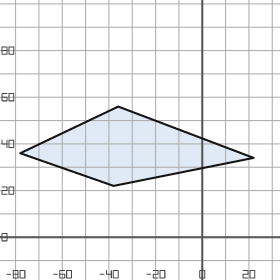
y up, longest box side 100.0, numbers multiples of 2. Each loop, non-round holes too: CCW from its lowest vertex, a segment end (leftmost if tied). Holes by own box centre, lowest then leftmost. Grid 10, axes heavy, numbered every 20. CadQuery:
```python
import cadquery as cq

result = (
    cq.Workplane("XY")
    .moveTo(-38.0, 22.0)
    .lineTo(22.0, 34.0)
    .lineTo(-36.0, 56.0)
    .lineTo(-78.0, 36.0)
    .close()
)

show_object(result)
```